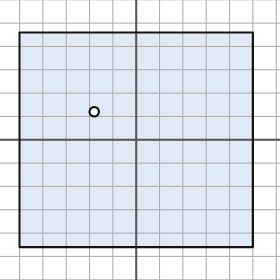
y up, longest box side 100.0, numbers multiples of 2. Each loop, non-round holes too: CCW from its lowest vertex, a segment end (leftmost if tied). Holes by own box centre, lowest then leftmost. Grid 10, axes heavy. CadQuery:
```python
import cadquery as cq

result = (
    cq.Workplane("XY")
    .moveTo(-50.0, -46.0)
    .lineTo(50.0, -46.0)
    .lineTo(50.0, 46.0)
    .lineTo(-50.0, 46.0)
    .close()
    .moveTo(-18.0, 12.0)
    .circle(2.0)
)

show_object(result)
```